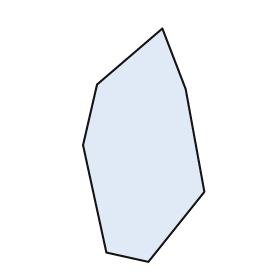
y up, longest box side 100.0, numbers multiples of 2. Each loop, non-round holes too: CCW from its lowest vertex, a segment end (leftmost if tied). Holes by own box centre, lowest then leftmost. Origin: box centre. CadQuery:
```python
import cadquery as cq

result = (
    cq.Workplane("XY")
    .moveTo(2.0, -50.0)
    .lineTo(26.0, -20.0)
    .lineTo(18.0, 24.0)
    .lineTo(8.0, 50.0)
    .lineTo(-20.0, 26.0)
    .lineTo(-26.0, 0.0)
    .lineTo(-16.0, -46.0)
    .close()
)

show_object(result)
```